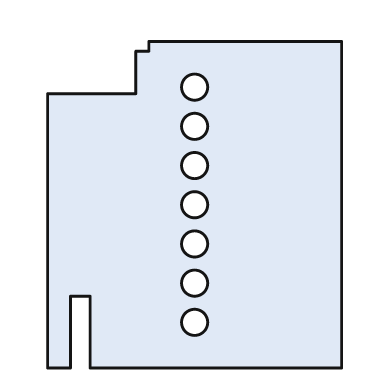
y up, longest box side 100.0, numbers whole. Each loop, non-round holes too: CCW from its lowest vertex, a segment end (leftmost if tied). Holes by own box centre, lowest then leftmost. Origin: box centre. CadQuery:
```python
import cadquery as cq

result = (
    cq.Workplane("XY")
    .moveTo(-45.0, -50.0)
    .lineTo(-38.0, -50.0)
    .lineTo(-38.0, -28.0)
    .lineTo(-32.0, -28.0)
    .lineTo(-32.0, -50.0)
    .lineTo(45.0, -50.0)
    .lineTo(45.0, 50.0)
    .lineTo(-14.0, 50.0)
    .lineTo(-14.0, 47.0)
    .lineTo(-18.0, 47.0)
    .lineTo(-18.0, 34.0)
    .lineTo(-45.0, 34.0)
    .close()
    .moveTo(0.0, -36.0)
    .circle(4.0)
    .moveTo(0.0, -24.0)
    .circle(4.0)
    .moveTo(0.0, -12.0)
    .circle(4.0)
    .moveTo(0.0, 0.0)
    .circle(4.0)
    .moveTo(0.0, 12.0)
    .circle(4.0)
    .moveTo(0.0, 24.0)
    .circle(4.0)
    .moveTo(0.0, 36.0)
    .circle(4.0)
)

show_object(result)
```